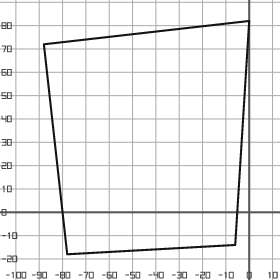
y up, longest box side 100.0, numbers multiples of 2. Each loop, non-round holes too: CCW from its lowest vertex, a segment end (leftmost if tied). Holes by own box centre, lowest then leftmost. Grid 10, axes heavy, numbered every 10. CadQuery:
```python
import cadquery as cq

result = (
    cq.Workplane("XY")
    .moveTo(-78.0, -18.0)
    .lineTo(-6.0, -14.0)
    .lineTo(0.0, 82.0)
    .lineTo(-88.0, 72.0)
    .close()
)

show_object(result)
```